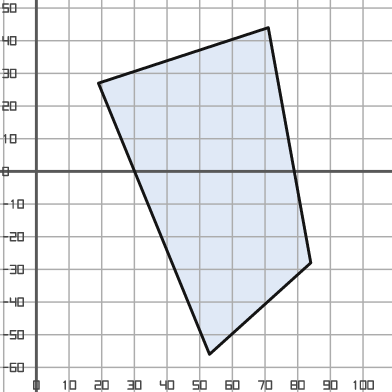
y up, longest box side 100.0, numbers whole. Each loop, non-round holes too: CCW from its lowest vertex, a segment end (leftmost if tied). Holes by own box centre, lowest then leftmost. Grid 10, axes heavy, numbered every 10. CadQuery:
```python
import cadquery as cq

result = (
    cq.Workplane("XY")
    .moveTo(53.0, -56.0)
    .lineTo(84.0, -28.0)
    .lineTo(71.0, 44.0)
    .lineTo(19.0, 27.0)
    .close()
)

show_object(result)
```